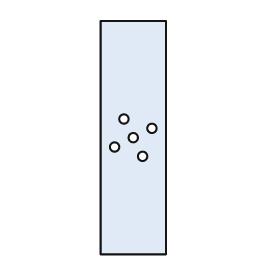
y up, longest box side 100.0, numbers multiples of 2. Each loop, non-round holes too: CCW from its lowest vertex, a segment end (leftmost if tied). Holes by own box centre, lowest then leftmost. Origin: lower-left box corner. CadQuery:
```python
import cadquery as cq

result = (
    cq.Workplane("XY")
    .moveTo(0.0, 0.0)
    .lineTo(28.0, 0.0)
    .lineTo(28.0, 100.0)
    .lineTo(0.0, 100.0)
    .close()
    .moveTo(18.0, 42.0)
    .circle(2.0)
    .moveTo(6.0, 46.0)
    .circle(2.0)
    .moveTo(14.0, 50.0)
    .circle(2.0)
    .moveTo(22.0, 54.0)
    .circle(2.0)
    .moveTo(10.0, 58.0)
    .circle(2.0)
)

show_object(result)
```